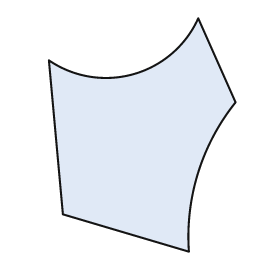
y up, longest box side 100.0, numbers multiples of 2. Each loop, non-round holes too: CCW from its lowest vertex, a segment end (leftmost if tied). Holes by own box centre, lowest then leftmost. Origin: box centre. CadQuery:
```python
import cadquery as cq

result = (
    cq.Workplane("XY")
    .moveTo(20.0, -50.0)
    .threePointArc((24.0, -16.0), (40.0, 14.0))
    .lineTo(24.0, 50.0)
    .threePointArc((-4.0, 26.0), (-40.0, 32.0))
    .lineTo(-34.0, -34.0)
    .close()
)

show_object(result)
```